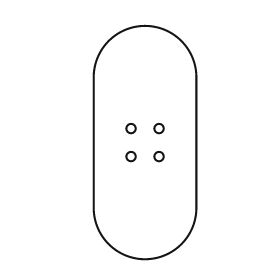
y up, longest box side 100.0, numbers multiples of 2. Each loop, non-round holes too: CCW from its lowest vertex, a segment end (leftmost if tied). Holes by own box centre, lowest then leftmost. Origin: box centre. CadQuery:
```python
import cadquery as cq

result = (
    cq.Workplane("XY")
    .moveTo(-22.0, -28.0)
    .threePointArc((0.0, -50.0), (22.0, -28.0))
    .lineTo(22.0, 28.0)
    .threePointArc((0.0, 50.0), (-22.0, 28.0))
    .close()
    .moveTo(-6.0, -6.0)
    .circle(2.0)
    .moveTo(6.0, -6.0)
    .circle(2.0)
    .moveTo(-6.0, 6.0)
    .circle(2.0)
    .moveTo(6.0, 6.0)
    .circle(2.0)
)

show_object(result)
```